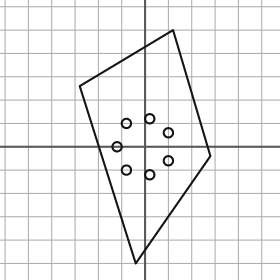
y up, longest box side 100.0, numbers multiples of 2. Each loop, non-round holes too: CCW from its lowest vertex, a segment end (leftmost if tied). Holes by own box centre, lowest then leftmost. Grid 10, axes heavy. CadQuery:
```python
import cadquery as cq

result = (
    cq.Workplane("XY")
    .moveTo(-4.0, -50.0)
    .lineTo(28.0, -4.0)
    .lineTo(12.0, 50.0)
    .lineTo(-28.0, 26.0)
    .close()
    .moveTo(2.0, -12.0)
    .circle(2.0)
    .moveTo(-8.0, -10.0)
    .circle(2.0)
    .moveTo(10.0, -6.0)
    .circle(2.0)
    .moveTo(-12.0, 0.0)
    .circle(2.0)
    .moveTo(10.0, 6.0)
    .circle(2.0)
    .moveTo(-8.0, 10.0)
    .circle(2.0)
    .moveTo(2.0, 12.0)
    .circle(2.0)
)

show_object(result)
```